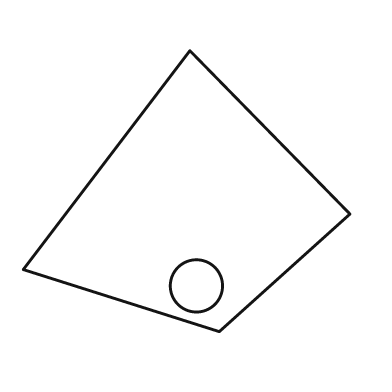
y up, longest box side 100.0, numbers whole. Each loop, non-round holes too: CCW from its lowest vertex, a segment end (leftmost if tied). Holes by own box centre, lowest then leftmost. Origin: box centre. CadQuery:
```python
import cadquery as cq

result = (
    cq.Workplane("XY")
    .moveTo(10.0, -43.0)
    .lineTo(50.0, -7.0)
    .lineTo(1.0, 43.0)
    .lineTo(-50.0, -24.0)
    .close()
    .moveTo(3.0, -29.0)
    .circle(8.0)
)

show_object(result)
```